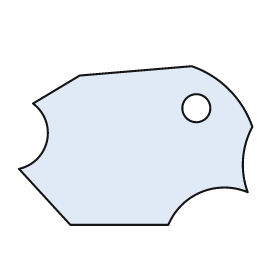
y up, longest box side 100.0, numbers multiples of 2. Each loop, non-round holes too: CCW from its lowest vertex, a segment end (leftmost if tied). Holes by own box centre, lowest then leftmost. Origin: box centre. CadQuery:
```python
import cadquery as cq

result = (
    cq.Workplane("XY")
    .moveTo(-28.0, -34.0)
    .lineTo(14.0, -34.0)
    .threePointArc((28.0, -20.0), (48.0, -20.0))
    .threePointArc((46.0, -6.0), (50.0, 8.0))
    .threePointArc((40.0, 24.0), (24.0, 34.0))
    .lineTo(-24.0, 30.0)
    .lineTo(-44.0, 18.0)
    .threePointArc((-38.0, 2.0), (-50.0, -10.0))
    .close()
    .moveTo(26.0, 16.0)
    .circle(6.0)
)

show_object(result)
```